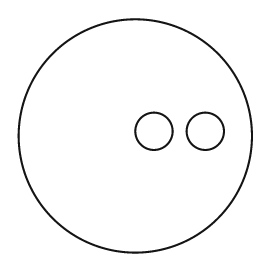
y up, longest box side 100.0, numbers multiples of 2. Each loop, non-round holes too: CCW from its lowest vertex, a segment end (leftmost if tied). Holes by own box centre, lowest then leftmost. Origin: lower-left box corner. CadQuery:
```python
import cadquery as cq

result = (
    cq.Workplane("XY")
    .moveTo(50.0, 50.0)
    .circle(50.0)
    .moveTo(58.0, 52.0)
    .circle(8.0)
    .moveTo(80.0, 52.0)
    .circle(8.0)
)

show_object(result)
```